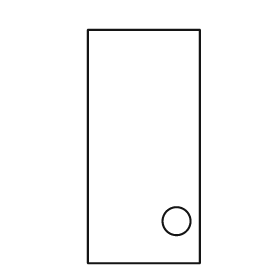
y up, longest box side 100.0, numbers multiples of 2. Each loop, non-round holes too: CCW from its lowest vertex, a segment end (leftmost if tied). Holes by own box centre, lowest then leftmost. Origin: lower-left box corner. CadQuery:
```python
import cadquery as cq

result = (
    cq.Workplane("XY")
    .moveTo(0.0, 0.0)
    .lineTo(48.0, 0.0)
    .lineTo(48.0, 100.0)
    .lineTo(0.0, 100.0)
    .close()
    .moveTo(38.0, 18.0)
    .circle(6.0)
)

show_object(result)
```